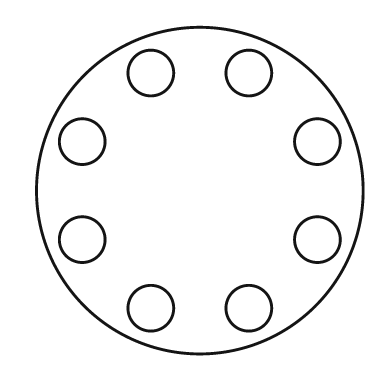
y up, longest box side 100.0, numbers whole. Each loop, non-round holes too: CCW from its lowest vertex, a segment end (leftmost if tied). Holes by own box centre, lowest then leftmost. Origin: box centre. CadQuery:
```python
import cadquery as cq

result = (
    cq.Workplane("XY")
    .moveTo(0.0, 0.0)
    .circle(50.0)
    .moveTo(-15.0, -36.0)
    .circle(7.0)
    .moveTo(15.0, -36.0)
    .circle(7.0)
    .moveTo(-36.0, -15.0)
    .circle(7.0)
    .moveTo(36.0, -15.0)
    .circle(7.0)
    .moveTo(-36.0, 15.0)
    .circle(7.0)
    .moveTo(36.0, 15.0)
    .circle(7.0)
    .moveTo(-15.0, 36.0)
    .circle(7.0)
    .moveTo(15.0, 36.0)
    .circle(7.0)
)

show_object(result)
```